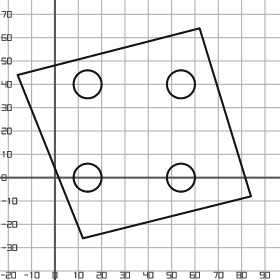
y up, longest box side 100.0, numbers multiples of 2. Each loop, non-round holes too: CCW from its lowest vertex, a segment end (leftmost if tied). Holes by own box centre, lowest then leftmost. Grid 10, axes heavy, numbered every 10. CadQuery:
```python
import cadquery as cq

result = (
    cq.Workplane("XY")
    .moveTo(12.0, -26.0)
    .lineTo(84.0, -8.0)
    .lineTo(62.0, 64.0)
    .lineTo(-16.0, 44.0)
    .close()
    .moveTo(14.0, 0.0)
    .circle(6.0)
    .moveTo(54.0, 0.0)
    .circle(6.0)
    .moveTo(14.0, 40.0)
    .circle(6.0)
    .moveTo(54.0, 40.0)
    .circle(6.0)
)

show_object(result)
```